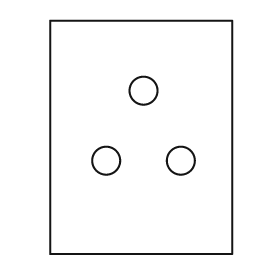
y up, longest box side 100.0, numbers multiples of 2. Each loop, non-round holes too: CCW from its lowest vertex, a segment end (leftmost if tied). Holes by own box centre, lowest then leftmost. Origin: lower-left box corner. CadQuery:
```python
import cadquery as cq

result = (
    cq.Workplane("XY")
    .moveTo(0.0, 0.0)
    .lineTo(78.0, 0.0)
    .lineTo(78.0, 100.0)
    .lineTo(0.0, 100.0)
    .close()
    .moveTo(24.0, 40.0)
    .circle(6.0)
    .moveTo(56.0, 40.0)
    .circle(6.0)
    .moveTo(40.0, 70.0)
    .circle(6.0)
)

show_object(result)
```